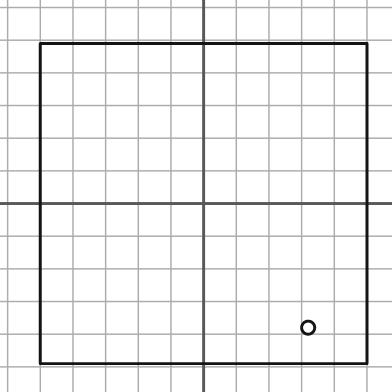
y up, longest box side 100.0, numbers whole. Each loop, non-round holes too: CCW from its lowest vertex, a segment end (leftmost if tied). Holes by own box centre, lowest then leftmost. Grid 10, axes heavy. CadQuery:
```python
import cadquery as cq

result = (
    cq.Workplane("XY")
    .moveTo(-50.0, -49.0)
    .lineTo(50.0, -49.0)
    .lineTo(50.0, 49.0)
    .lineTo(-50.0, 49.0)
    .close()
    .moveTo(32.0, -38.0)
    .circle(2.0)
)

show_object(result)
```